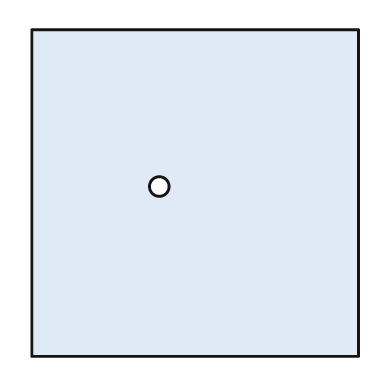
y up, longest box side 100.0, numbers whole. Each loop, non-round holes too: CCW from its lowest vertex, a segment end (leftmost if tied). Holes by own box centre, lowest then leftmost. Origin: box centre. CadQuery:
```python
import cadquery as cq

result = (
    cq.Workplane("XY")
    .moveTo(-50.0, -50.0)
    .lineTo(50.0, -50.0)
    .lineTo(50.0, 50.0)
    .lineTo(-50.0, 50.0)
    .close()
    .moveTo(-11.0, 2.0)
    .circle(3.0)
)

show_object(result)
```